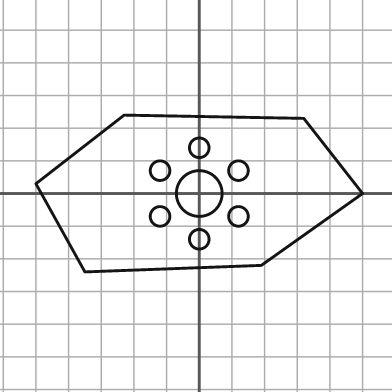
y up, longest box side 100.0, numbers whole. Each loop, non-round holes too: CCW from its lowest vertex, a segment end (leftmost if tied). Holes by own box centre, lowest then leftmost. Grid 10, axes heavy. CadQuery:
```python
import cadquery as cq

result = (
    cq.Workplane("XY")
    .moveTo(-35.0, -24.0)
    .lineTo(19.0, -22.0)
    .lineTo(50.0, 0.0)
    .lineTo(32.0, 23.0)
    .lineTo(-23.0, 24.0)
    .lineTo(-50.0, 3.0)
    .close()
    .moveTo(0.0, -14.0)
    .circle(3.0)
    .moveTo(-12.0, -7.0)
    .circle(3.0)
    .moveTo(12.0, -7.0)
    .circle(3.0)
    .moveTo(0.0, 0.0)
    .circle(7.0)
    .moveTo(-12.0, 7.0)
    .circle(3.0)
    .moveTo(12.0, 7.0)
    .circle(3.0)
    .moveTo(0.0, 14.0)
    .circle(3.0)
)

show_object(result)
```